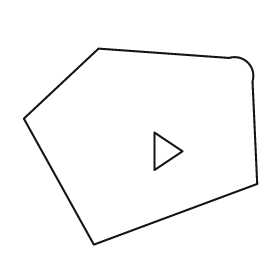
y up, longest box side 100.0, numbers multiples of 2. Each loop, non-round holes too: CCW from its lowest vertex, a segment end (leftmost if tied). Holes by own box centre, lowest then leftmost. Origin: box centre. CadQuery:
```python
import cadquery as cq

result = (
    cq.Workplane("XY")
    .moveTo(-20.0, -42.0)
    .lineTo(50.0, -16.0)
    .lineTo(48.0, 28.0)
    .threePointArc((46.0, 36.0), (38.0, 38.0))
    .lineTo(-18.0, 42.0)
    .lineTo(-50.0, 12.0)
    .close()
    .moveTo(6.0, -10.0)
    .lineTo(18.0, -2.0)
    .lineTo(6.0, 6.0)
    .close()
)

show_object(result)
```